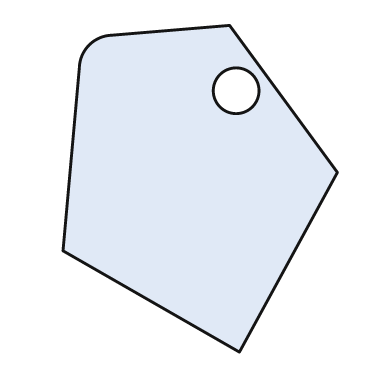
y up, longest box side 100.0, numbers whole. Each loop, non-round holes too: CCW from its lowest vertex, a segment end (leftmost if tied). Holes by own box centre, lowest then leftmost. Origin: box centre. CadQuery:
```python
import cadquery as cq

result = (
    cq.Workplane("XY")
    .moveTo(12.0, -50.0)
    .lineTo(42.0, 5.0)
    .lineTo(9.0, 50.0)
    .lineTo(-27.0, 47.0)
    .threePointArc((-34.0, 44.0), (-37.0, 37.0))
    .lineTo(-42.0, -19.0)
    .close()
    .moveTo(11.0, 30.0)
    .circle(7.0)
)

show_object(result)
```